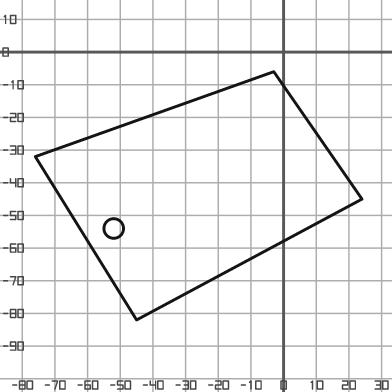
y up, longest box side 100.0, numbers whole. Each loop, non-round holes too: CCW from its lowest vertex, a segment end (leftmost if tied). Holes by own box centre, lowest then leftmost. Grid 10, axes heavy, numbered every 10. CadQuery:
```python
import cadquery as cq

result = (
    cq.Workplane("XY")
    .moveTo(-45.0, -82.0)
    .lineTo(24.0, -45.0)
    .lineTo(-3.0, -6.0)
    .lineTo(-76.0, -32.0)
    .close()
    .moveTo(-52.0, -54.0)
    .circle(3.0)
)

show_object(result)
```